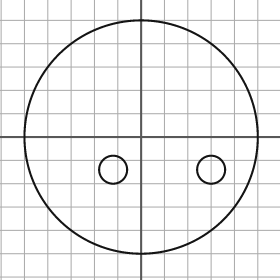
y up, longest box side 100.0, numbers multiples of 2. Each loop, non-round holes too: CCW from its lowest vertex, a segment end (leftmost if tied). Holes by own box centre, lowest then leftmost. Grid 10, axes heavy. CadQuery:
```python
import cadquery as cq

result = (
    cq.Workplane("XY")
    .moveTo(0.0, 0.0)
    .circle(50.0)
    .moveTo(-12.0, -14.0)
    .circle(6.0)
    .moveTo(30.0, -14.0)
    .circle(6.0)
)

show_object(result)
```